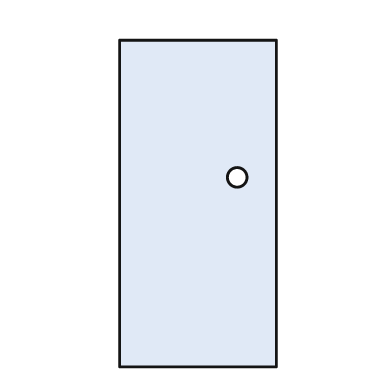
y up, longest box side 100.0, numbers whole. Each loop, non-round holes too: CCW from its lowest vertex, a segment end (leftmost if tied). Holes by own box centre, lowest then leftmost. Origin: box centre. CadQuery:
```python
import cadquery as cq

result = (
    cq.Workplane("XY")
    .moveTo(-24.0, -50.0)
    .lineTo(24.0, -50.0)
    .lineTo(24.0, 50.0)
    .lineTo(-24.0, 50.0)
    .close()
    .moveTo(12.0, 8.0)
    .circle(3.0)
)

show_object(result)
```